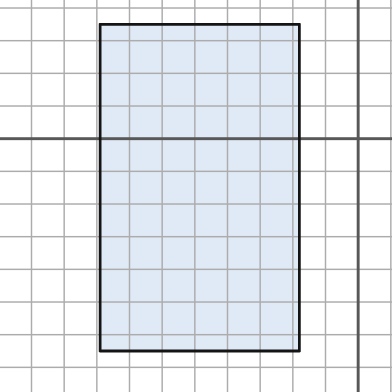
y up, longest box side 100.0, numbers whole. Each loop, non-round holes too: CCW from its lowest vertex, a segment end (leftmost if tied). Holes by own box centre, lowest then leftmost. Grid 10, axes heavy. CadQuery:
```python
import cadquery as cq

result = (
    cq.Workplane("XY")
    .moveTo(-79.0, -65.0)
    .lineTo(-18.0, -65.0)
    .lineTo(-18.0, 35.0)
    .lineTo(-79.0, 35.0)
    .close()
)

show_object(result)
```